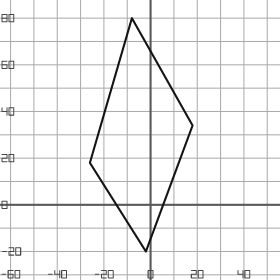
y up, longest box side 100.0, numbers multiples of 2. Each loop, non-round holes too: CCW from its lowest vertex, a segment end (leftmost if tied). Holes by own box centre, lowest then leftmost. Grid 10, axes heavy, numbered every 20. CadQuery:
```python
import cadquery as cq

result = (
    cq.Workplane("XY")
    .moveTo(-2.0, -20.0)
    .lineTo(18.0, 34.0)
    .lineTo(-8.0, 80.0)
    .lineTo(-26.0, 18.0)
    .close()
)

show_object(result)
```